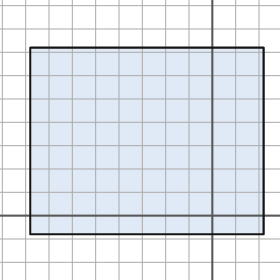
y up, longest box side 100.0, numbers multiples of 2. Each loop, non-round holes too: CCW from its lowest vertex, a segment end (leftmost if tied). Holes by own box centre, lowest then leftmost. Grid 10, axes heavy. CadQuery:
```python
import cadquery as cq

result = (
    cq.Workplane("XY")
    .moveTo(-78.0, -8.0)
    .lineTo(22.0, -8.0)
    .lineTo(22.0, 72.0)
    .lineTo(-78.0, 72.0)
    .close()
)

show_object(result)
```